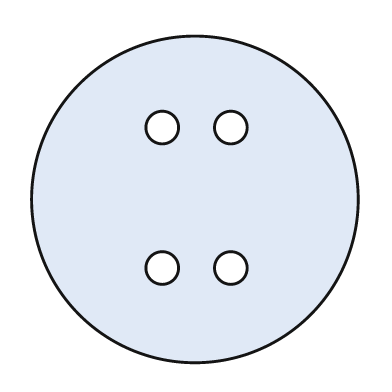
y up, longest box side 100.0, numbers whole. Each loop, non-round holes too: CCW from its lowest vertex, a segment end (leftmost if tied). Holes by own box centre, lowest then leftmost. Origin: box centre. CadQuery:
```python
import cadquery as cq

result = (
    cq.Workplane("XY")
    .moveTo(0.0, 0.0)
    .circle(50.0)
    .moveTo(-10.0, -21.0)
    .circle(5.0)
    .moveTo(11.0, -21.0)
    .circle(5.0)
    .moveTo(-10.0, 22.0)
    .circle(5.0)
    .moveTo(11.0, 22.0)
    .circle(5.0)
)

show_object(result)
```